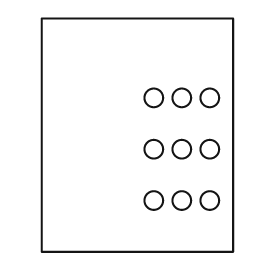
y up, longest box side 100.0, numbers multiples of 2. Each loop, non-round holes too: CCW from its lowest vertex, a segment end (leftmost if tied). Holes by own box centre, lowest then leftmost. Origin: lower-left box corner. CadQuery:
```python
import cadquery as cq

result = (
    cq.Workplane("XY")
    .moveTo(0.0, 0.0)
    .lineTo(82.0, 0.0)
    .lineTo(82.0, 100.0)
    .lineTo(0.0, 100.0)
    .close()
    .moveTo(48.0, 22.0)
    .circle(4.0)
    .moveTo(60.0, 22.0)
    .circle(4.0)
    .moveTo(72.0, 22.0)
    .circle(4.0)
    .moveTo(48.0, 44.0)
    .circle(4.0)
    .moveTo(60.0, 44.0)
    .circle(4.0)
    .moveTo(72.0, 44.0)
    .circle(4.0)
    .moveTo(48.0, 66.0)
    .circle(4.0)
    .moveTo(60.0, 66.0)
    .circle(4.0)
    .moveTo(72.0, 66.0)
    .circle(4.0)
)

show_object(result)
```